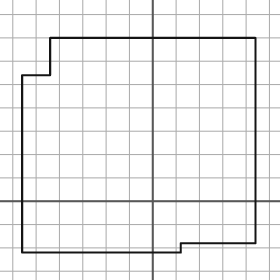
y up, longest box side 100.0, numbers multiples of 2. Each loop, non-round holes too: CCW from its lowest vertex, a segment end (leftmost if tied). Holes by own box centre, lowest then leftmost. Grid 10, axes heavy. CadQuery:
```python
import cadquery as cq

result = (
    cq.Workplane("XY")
    .moveTo(-56.0, -22.0)
    .lineTo(12.0, -22.0)
    .lineTo(12.0, -18.0)
    .lineTo(44.0, -18.0)
    .lineTo(44.0, 70.0)
    .lineTo(-44.0, 70.0)
    .lineTo(-44.0, 54.0)
    .lineTo(-56.0, 54.0)
    .close()
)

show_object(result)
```